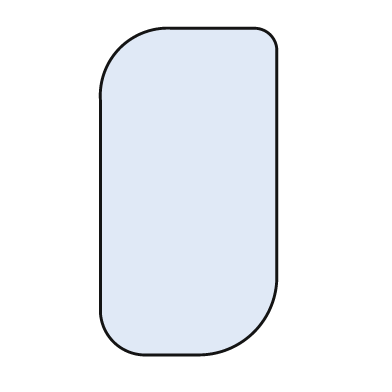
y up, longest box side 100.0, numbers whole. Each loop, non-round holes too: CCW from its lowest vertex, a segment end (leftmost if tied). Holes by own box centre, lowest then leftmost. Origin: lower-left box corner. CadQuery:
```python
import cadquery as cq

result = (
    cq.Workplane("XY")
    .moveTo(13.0, 0.0)
    .lineTo(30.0, 0.0)
    .threePointArc((47.0, 7.0), (54.0, 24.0))
    .lineTo(54.0, 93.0)
    .threePointArc((52.0, 98.0), (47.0, 100.0))
    .lineTo(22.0, 100.0)
    .threePointArc((6.0, 94.0), (0.0, 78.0))
    .lineTo(0.0, 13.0)
    .threePointArc((4.0, 4.0), (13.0, 0.0))
    .close()
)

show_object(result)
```